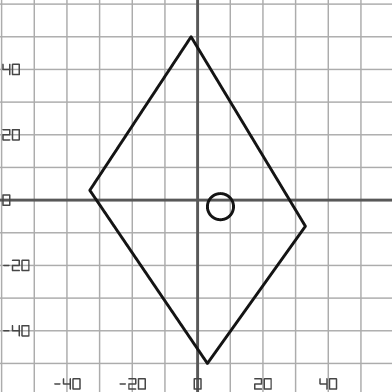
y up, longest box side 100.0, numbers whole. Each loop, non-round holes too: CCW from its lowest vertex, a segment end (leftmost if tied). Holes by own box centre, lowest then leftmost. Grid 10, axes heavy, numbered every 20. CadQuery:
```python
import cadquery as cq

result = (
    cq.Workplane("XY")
    .moveTo(3.0, -50.0)
    .lineTo(33.0, -8.0)
    .lineTo(-2.0, 50.0)
    .lineTo(-33.0, 3.0)
    .close()
    .moveTo(7.0, -2.0)
    .circle(4.0)
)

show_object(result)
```